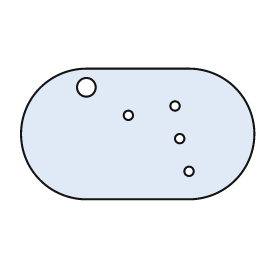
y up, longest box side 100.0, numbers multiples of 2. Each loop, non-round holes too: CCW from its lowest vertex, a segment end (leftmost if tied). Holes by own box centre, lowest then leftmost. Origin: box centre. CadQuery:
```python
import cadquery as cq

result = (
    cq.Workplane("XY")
    .moveTo(-22.0, -28.0)
    .lineTo(22.0, -28.0)
    .threePointArc((50.0, 0.0), (22.0, 28.0))
    .lineTo(-22.0, 28.0)
    .threePointArc((-50.0, 0.0), (-22.0, -28.0))
    .close()
    .moveTo(22.0, -16.0)
    .circle(2.0)
    .moveTo(18.0, -2.0)
    .circle(2.0)
    .moveTo(-4.0, 8.0)
    .circle(2.0)
    .moveTo(16.0, 12.0)
    .circle(2.0)
    .moveTo(-22.0, 20.0)
    .circle(4.0)
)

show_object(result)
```